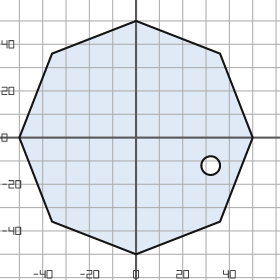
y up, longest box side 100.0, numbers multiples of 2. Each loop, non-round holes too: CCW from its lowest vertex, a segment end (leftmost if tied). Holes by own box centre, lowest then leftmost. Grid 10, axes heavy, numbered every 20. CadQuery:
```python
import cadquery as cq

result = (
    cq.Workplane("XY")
    .moveTo(0.0, -50.0)
    .lineTo(36.0, -36.0)
    .lineTo(50.0, 0.0)
    .lineTo(36.0, 36.0)
    .lineTo(0.0, 50.0)
    .lineTo(-36.0, 36.0)
    .lineTo(-50.0, 0.0)
    .lineTo(-36.0, -36.0)
    .close()
    .moveTo(32.0, -12.0)
    .circle(4.0)
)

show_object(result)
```